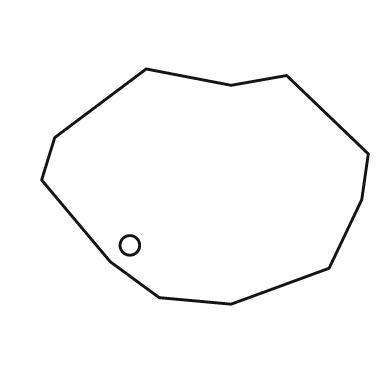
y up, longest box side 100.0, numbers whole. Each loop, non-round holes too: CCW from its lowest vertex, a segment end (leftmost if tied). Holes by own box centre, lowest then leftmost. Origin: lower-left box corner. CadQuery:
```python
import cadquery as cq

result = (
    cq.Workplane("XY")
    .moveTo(58.0, 0.0)
    .lineTo(88.0, 11.0)
    .lineTo(98.0, 32.0)
    .lineTo(100.0, 46.0)
    .lineTo(75.0, 70.0)
    .lineTo(58.0, 67.0)
    .lineTo(32.0, 72.0)
    .lineTo(4.0, 51.0)
    .lineTo(0.0, 38.0)
    .lineTo(21.0, 13.0)
    .lineTo(36.0, 2.0)
    .close()
    .moveTo(27.0, 18.0)
    .circle(3.0)
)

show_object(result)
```